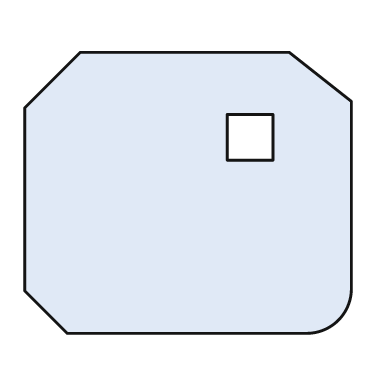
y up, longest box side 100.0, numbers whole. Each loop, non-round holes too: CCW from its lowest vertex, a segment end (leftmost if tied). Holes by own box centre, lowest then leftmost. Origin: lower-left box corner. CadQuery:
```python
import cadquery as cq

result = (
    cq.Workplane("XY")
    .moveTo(13.0, 0.0)
    .lineTo(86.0, 0.0)
    .threePointArc((96.0, 4.0), (100.0, 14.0))
    .lineTo(100.0, 71.0)
    .lineTo(81.0, 86.0)
    .lineTo(17.0, 86.0)
    .lineTo(0.0, 69.0)
    .lineTo(0.0, 13.0)
    .close()
    .moveTo(62.0, 53.0)
    .lineTo(76.0, 53.0)
    .lineTo(76.0, 67.0)
    .lineTo(62.0, 67.0)
    .close()
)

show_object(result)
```